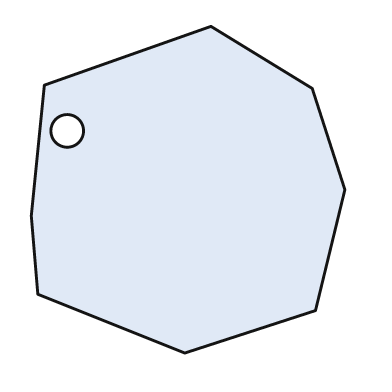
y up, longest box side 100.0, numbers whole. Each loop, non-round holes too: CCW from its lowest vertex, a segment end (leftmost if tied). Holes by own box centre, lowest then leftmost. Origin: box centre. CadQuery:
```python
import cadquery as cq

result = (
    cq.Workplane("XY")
    .moveTo(-1.0, -50.0)
    .lineTo(39.0, -37.0)
    .lineTo(48.0, 0.0)
    .lineTo(38.0, 31.0)
    .lineTo(7.0, 50.0)
    .lineTo(-44.0, 32.0)
    .lineTo(-48.0, -8.0)
    .lineTo(-46.0, -32.0)
    .close()
    .moveTo(-37.0, 18.0)
    .circle(5.0)
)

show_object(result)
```